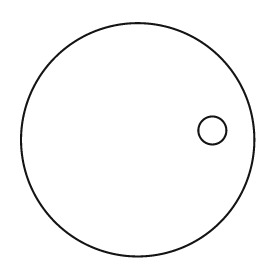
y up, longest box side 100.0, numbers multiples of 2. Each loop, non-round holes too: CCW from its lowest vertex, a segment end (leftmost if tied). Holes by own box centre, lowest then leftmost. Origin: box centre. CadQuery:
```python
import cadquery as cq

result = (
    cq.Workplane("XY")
    .moveTo(0.0, 0.0)
    .circle(50.0)
    .moveTo(32.0, 4.0)
    .circle(6.0)
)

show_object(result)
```